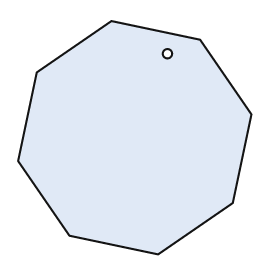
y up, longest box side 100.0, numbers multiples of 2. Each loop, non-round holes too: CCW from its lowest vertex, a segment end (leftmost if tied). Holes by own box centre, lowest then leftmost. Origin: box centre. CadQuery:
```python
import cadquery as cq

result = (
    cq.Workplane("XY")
    .moveTo(10.0, -50.0)
    .lineTo(42.0, -28.0)
    .lineTo(50.0, 10.0)
    .lineTo(28.0, 42.0)
    .lineTo(-10.0, 50.0)
    .lineTo(-42.0, 28.0)
    .lineTo(-50.0, -10.0)
    .lineTo(-28.0, -42.0)
    .close()
    .moveTo(14.0, 36.0)
    .circle(2.0)
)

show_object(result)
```